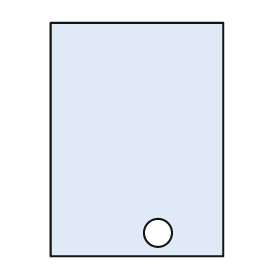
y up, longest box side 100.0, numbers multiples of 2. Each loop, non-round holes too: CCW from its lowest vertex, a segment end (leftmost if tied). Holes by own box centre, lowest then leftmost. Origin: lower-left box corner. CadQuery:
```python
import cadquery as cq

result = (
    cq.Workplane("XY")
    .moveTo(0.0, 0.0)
    .lineTo(74.0, 0.0)
    .lineTo(74.0, 100.0)
    .lineTo(0.0, 100.0)
    .close()
    .moveTo(46.0, 10.0)
    .circle(6.0)
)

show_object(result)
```